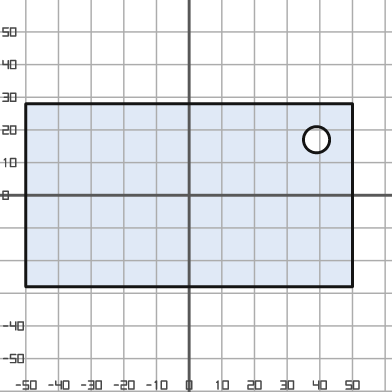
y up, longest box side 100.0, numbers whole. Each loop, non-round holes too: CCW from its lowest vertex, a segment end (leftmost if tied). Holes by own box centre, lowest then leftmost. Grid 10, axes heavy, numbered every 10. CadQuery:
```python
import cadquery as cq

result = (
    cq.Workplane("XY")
    .moveTo(-50.0, -28.0)
    .lineTo(50.0, -28.0)
    .lineTo(50.0, 28.0)
    .lineTo(-50.0, 28.0)
    .close()
    .moveTo(39.0, 17.0)
    .circle(4.0)
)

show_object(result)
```